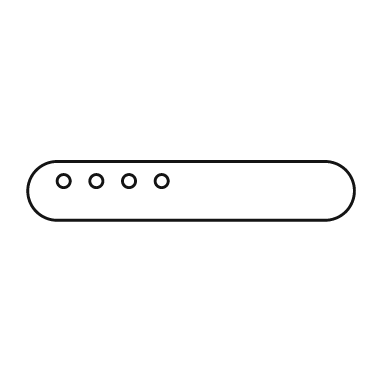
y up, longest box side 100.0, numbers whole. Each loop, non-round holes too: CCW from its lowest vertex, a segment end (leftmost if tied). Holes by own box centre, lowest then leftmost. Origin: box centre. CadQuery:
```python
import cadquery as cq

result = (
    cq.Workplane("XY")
    .moveTo(-41.0, -9.0)
    .lineTo(41.0, -9.0)
    .threePointArc((50.0, 0.0), (41.0, 9.0))
    .lineTo(-41.0, 9.0)
    .threePointArc((-50.0, 0.0), (-41.0, -9.0))
    .close()
    .moveTo(-39.0, 3.0)
    .circle(2.0)
    .moveTo(-29.0, 3.0)
    .circle(2.0)
    .moveTo(-19.0, 3.0)
    .circle(2.0)
    .moveTo(-9.0, 3.0)
    .circle(2.0)
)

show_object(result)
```